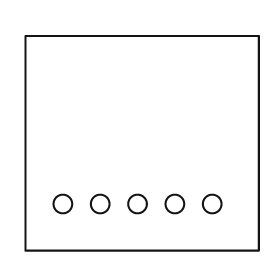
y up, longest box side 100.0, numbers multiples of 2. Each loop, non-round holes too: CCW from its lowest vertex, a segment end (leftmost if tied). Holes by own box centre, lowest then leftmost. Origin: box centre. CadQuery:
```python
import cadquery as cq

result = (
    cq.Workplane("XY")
    .moveTo(-50.0, -46.0)
    .lineTo(50.0, -46.0)
    .lineTo(50.0, 46.0)
    .lineTo(-50.0, 46.0)
    .close()
    .moveTo(-34.0, -26.0)
    .circle(4.0)
    .moveTo(-18.0, -26.0)
    .circle(4.0)
    .moveTo(-2.0, -26.0)
    .circle(4.0)
    .moveTo(14.0, -26.0)
    .circle(4.0)
    .moveTo(30.0, -26.0)
    .circle(4.0)
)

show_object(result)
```